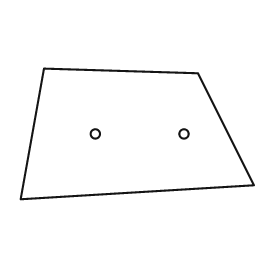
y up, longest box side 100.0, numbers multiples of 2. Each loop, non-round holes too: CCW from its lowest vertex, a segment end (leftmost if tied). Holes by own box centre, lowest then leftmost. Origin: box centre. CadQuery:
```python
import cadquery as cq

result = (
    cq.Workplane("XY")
    .moveTo(-50.0, -28.0)
    .lineTo(50.0, -22.0)
    .lineTo(26.0, 26.0)
    .lineTo(-40.0, 28.0)
    .close()
    .moveTo(-18.0, 0.0)
    .circle(2.0)
    .moveTo(20.0, 0.0)
    .circle(2.0)
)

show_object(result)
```